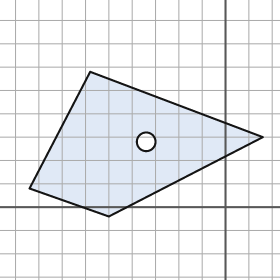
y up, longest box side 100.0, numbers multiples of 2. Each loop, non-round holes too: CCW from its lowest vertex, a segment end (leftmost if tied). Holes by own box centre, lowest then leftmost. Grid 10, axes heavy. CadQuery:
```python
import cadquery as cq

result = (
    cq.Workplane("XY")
    .moveTo(-50.0, -4.0)
    .lineTo(16.0, 30.0)
    .lineTo(-58.0, 58.0)
    .lineTo(-84.0, 8.0)
    .close()
    .moveTo(-34.0, 28.0)
    .circle(4.0)
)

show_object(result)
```